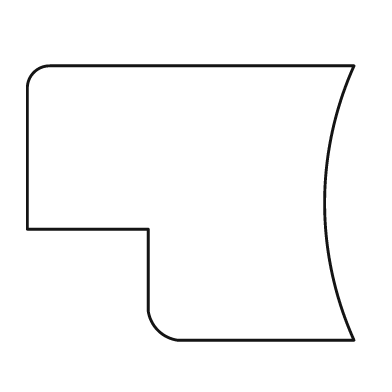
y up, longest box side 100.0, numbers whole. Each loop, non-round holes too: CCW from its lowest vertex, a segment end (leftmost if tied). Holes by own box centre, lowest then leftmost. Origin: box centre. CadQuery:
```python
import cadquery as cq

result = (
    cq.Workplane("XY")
    .moveTo(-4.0, -42.0)
    .lineTo(50.0, -42.0)
    .threePointArc((41.0, 0.0), (50.0, 42.0))
    .lineTo(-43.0, 42.0)
    .threePointArc((-48.0, 40.0), (-50.0, 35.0))
    .lineTo(-50.0, -8.0)
    .lineTo(-13.0, -8.0)
    .lineTo(-13.0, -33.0)
    .threePointArc((-10.0, -39.0), (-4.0, -42.0))
    .close()
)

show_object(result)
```